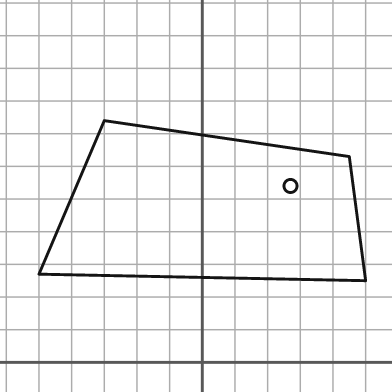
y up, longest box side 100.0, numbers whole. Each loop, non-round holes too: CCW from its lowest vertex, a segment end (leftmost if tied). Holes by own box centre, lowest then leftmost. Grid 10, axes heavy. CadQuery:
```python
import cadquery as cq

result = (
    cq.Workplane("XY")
    .moveTo(50.0, 25.0)
    .lineTo(45.0, 63.0)
    .lineTo(-30.0, 74.0)
    .lineTo(-50.0, 27.0)
    .close()
    .moveTo(27.0, 54.0)
    .circle(2.0)
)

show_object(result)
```